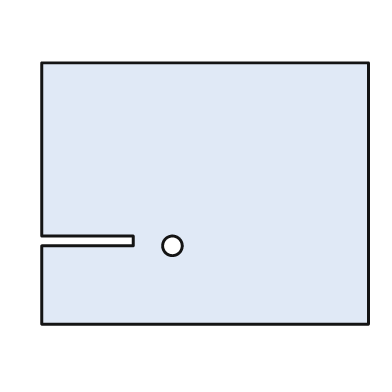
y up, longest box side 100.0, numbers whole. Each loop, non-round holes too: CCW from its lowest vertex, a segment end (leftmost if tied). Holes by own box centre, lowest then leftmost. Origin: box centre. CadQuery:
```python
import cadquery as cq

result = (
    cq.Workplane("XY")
    .moveTo(-50.0, -40.0)
    .lineTo(50.0, -40.0)
    .lineTo(50.0, 40.0)
    .lineTo(-50.0, 40.0)
    .lineTo(-50.0, -13.0)
    .lineTo(-22.0, -13.0)
    .lineTo(-22.0, -16.0)
    .lineTo(-50.0, -16.0)
    .close()
    .moveTo(-10.0, -16.0)
    .circle(3.0)
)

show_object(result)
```